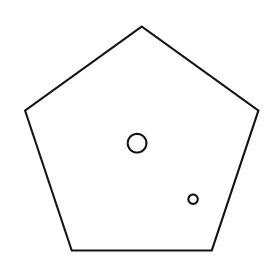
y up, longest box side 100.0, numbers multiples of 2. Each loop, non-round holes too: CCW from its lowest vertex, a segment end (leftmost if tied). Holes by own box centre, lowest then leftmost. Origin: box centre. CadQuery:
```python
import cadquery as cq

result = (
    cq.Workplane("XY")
    .moveTo(-30.0, -48.0)
    .lineTo(30.0, -48.0)
    .lineTo(50.0, 12.0)
    .lineTo(0.0, 48.0)
    .lineTo(-50.0, 12.0)
    .close()
    .moveTo(22.0, -26.0)
    .circle(2.0)
    .moveTo(-2.0, -2.0)
    .circle(4.0)
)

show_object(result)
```